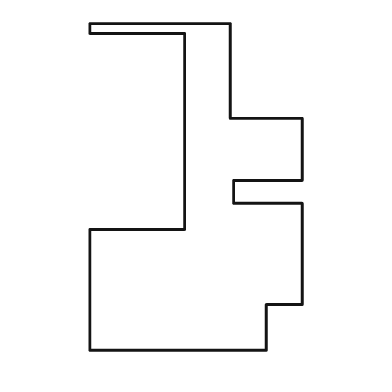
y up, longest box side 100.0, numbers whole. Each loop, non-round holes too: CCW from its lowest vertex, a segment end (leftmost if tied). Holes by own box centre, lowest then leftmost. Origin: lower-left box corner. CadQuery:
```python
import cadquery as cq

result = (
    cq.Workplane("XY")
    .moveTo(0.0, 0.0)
    .lineTo(54.0, 0.0)
    .lineTo(54.0, 14.0)
    .lineTo(65.0, 14.0)
    .lineTo(65.0, 45.0)
    .lineTo(44.0, 45.0)
    .lineTo(44.0, 52.0)
    .lineTo(65.0, 52.0)
    .lineTo(65.0, 71.0)
    .lineTo(43.0, 71.0)
    .lineTo(43.0, 100.0)
    .lineTo(0.0, 100.0)
    .lineTo(0.0, 97.0)
    .lineTo(29.0, 97.0)
    .lineTo(29.0, 37.0)
    .lineTo(0.0, 37.0)
    .close()
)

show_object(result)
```